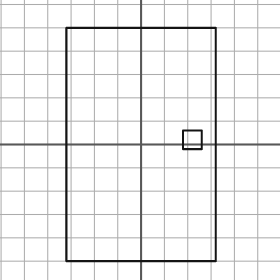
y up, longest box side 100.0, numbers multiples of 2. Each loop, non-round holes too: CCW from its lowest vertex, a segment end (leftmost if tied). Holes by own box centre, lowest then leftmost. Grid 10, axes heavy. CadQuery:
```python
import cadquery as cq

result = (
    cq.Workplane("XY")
    .moveTo(-32.0, -50.0)
    .lineTo(32.0, -50.0)
    .lineTo(32.0, 50.0)
    .lineTo(-32.0, 50.0)
    .close()
    .moveTo(18.0, -2.0)
    .lineTo(26.0, -2.0)
    .lineTo(26.0, 6.0)
    .lineTo(18.0, 6.0)
    .close()
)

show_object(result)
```